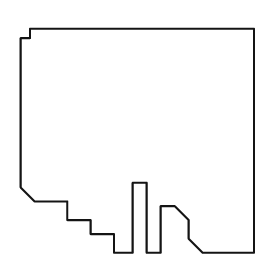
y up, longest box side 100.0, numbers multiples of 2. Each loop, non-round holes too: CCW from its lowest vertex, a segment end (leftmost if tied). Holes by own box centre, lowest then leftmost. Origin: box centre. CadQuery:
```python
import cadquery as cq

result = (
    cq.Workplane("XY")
    .moveTo(-10.0, -48.0)
    .lineTo(-2.0, -48.0)
    .lineTo(-2.0, -18.0)
    .lineTo(4.0, -18.0)
    .lineTo(4.0, -48.0)
    .lineTo(10.0, -48.0)
    .lineTo(10.0, -28.0)
    .lineTo(16.0, -28.0)
    .lineTo(22.0, -34.0)
    .lineTo(22.0, -42.0)
    .lineTo(28.0, -48.0)
    .lineTo(50.0, -48.0)
    .lineTo(50.0, 48.0)
    .lineTo(-46.0, 48.0)
    .lineTo(-46.0, 44.0)
    .lineTo(-50.0, 44.0)
    .lineTo(-50.0, -20.0)
    .lineTo(-44.0, -26.0)
    .lineTo(-30.0, -26.0)
    .lineTo(-30.0, -34.0)
    .lineTo(-20.0, -34.0)
    .lineTo(-20.0, -40.0)
    .lineTo(-10.0, -40.0)
    .close()
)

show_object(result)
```